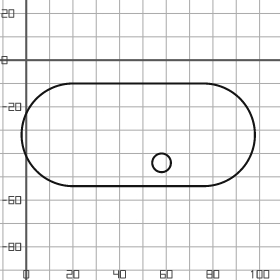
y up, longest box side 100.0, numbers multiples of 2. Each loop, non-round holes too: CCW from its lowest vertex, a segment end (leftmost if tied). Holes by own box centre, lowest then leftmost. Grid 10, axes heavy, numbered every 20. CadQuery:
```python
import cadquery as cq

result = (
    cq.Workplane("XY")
    .moveTo(20.0, -54.0)
    .lineTo(76.0, -54.0)
    .threePointArc((98.0, -32.0), (76.0, -10.0))
    .lineTo(20.0, -10.0)
    .threePointArc((-2.0, -32.0), (20.0, -54.0))
    .close()
    .moveTo(58.0, -44.0)
    .circle(4.0)
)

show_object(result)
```